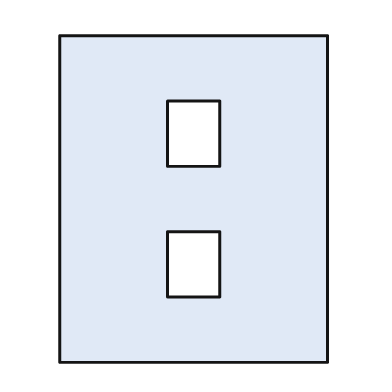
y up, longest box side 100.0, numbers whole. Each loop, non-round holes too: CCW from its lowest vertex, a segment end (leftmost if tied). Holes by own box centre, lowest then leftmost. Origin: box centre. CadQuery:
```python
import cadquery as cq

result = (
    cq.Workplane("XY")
    .moveTo(-41.0, -50.0)
    .lineTo(41.0, -50.0)
    .lineTo(41.0, 50.0)
    .lineTo(-41.0, 50.0)
    .close()
    .moveTo(-8.0, -30.0)
    .lineTo(8.0, -30.0)
    .lineTo(8.0, -10.0)
    .lineTo(-8.0, -10.0)
    .close()
    .moveTo(-8.0, 10.0)
    .lineTo(8.0, 10.0)
    .lineTo(8.0, 30.0)
    .lineTo(-8.0, 30.0)
    .close()
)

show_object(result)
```